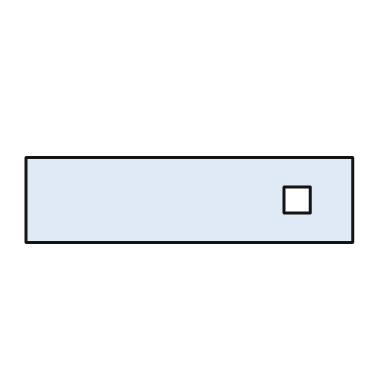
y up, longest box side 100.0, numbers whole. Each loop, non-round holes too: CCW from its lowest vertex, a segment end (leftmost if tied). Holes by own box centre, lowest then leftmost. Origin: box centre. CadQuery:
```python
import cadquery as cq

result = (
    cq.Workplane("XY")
    .moveTo(-50.0, -13.0)
    .lineTo(50.0, -13.0)
    .lineTo(50.0, 13.0)
    .lineTo(-50.0, 13.0)
    .close()
    .moveTo(29.0, -4.0)
    .lineTo(37.0, -4.0)
    .lineTo(37.0, 4.0)
    .lineTo(29.0, 4.0)
    .close()
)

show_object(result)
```